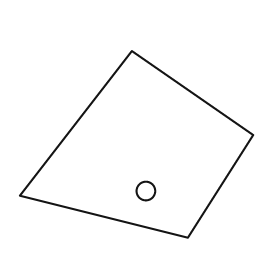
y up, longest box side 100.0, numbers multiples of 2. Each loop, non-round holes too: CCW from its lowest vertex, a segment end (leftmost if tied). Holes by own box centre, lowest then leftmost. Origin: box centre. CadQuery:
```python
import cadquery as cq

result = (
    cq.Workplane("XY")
    .moveTo(22.0, -40.0)
    .lineTo(50.0, 4.0)
    .lineTo(-2.0, 40.0)
    .lineTo(-50.0, -22.0)
    .close()
    .moveTo(4.0, -20.0)
    .circle(4.0)
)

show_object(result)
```